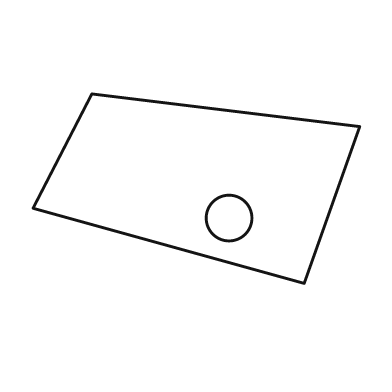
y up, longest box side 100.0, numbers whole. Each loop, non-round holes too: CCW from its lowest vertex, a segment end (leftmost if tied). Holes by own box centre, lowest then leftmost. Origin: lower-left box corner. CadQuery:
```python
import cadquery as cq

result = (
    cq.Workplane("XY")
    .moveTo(83.0, 0.0)
    .lineTo(100.0, 48.0)
    .lineTo(18.0, 58.0)
    .lineTo(0.0, 23.0)
    .close()
    .moveTo(60.0, 20.0)
    .circle(7.0)
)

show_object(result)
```